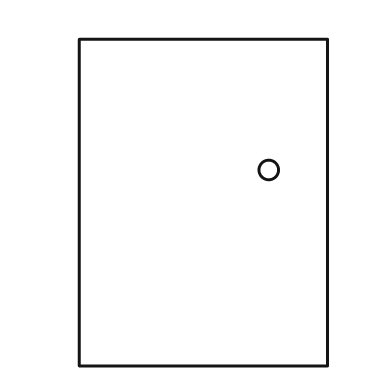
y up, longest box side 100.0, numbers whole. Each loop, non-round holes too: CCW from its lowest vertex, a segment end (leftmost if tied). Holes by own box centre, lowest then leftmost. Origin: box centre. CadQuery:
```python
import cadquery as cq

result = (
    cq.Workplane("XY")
    .moveTo(-38.0, -50.0)
    .lineTo(38.0, -50.0)
    .lineTo(38.0, 50.0)
    .lineTo(-38.0, 50.0)
    .close()
    .moveTo(20.0, 10.0)
    .circle(3.0)
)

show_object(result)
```